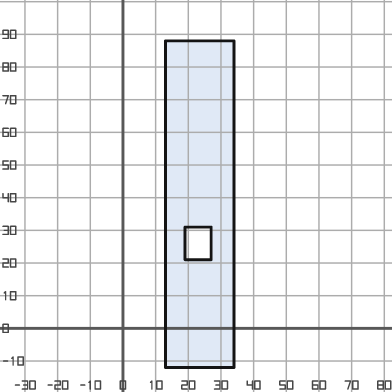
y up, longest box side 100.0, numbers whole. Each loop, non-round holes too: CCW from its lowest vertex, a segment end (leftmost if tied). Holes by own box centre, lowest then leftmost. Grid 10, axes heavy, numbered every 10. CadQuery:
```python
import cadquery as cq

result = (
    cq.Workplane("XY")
    .moveTo(13.0, -12.0)
    .lineTo(34.0, -12.0)
    .lineTo(34.0, 88.0)
    .lineTo(13.0, 88.0)
    .close()
    .moveTo(19.0, 21.0)
    .lineTo(27.0, 21.0)
    .lineTo(27.0, 31.0)
    .lineTo(19.0, 31.0)
    .close()
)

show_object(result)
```